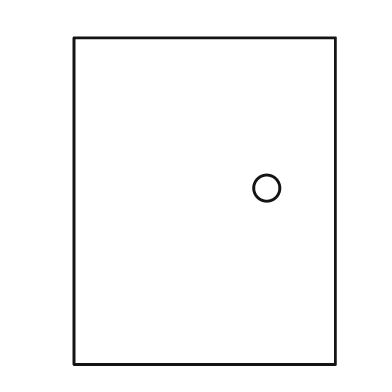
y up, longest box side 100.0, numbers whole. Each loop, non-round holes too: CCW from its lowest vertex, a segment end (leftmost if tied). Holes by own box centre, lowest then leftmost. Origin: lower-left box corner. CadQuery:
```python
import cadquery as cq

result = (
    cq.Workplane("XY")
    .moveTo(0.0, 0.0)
    .lineTo(80.0, 0.0)
    .lineTo(80.0, 100.0)
    .lineTo(0.0, 100.0)
    .close()
    .moveTo(59.0, 54.0)
    .circle(4.0)
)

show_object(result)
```